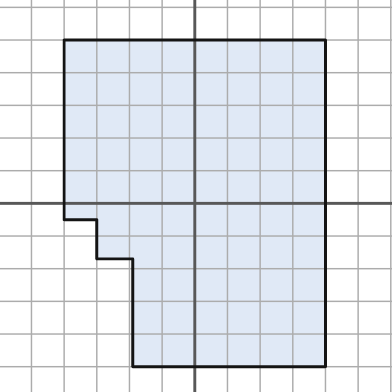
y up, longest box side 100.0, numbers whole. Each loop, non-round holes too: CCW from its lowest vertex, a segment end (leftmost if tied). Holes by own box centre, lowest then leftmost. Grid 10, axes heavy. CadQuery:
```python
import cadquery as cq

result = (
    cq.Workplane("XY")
    .moveTo(-19.0, -50.0)
    .lineTo(40.0, -50.0)
    .lineTo(40.0, 50.0)
    .lineTo(-40.0, 50.0)
    .lineTo(-40.0, -5.0)
    .lineTo(-30.0, -5.0)
    .lineTo(-30.0, -17.0)
    .lineTo(-19.0, -17.0)
    .close()
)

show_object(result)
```